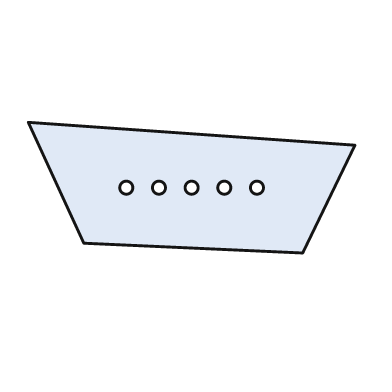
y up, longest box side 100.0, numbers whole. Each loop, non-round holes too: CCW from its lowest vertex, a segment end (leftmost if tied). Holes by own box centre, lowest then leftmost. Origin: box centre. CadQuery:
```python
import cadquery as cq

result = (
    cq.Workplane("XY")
    .moveTo(34.0, -20.0)
    .lineTo(50.0, 13.0)
    .lineTo(-50.0, 20.0)
    .lineTo(-33.0, -17.0)
    .close()
    .moveTo(-20.0, 0.0)
    .circle(2.0)
    .moveTo(-10.0, 0.0)
    .circle(2.0)
    .moveTo(0.0, 0.0)
    .circle(2.0)
    .moveTo(10.0, 0.0)
    .circle(2.0)
    .moveTo(20.0, 0.0)
    .circle(2.0)
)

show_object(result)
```